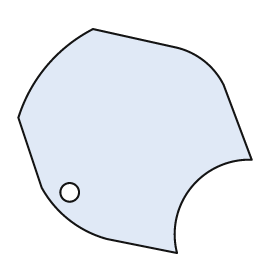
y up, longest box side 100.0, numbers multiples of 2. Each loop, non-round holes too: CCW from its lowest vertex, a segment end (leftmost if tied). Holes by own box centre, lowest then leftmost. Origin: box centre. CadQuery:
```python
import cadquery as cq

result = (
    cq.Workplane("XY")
    .moveTo(18.0, -48.0)
    .threePointArc((24.0, -20.0), (50.0, -8.0))
    .lineTo(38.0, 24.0)
    .threePointArc((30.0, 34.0), (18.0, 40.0))
    .lineTo(-18.0, 48.0)
    .threePointArc((-38.0, 32.0), (-50.0, 10.0))
    .lineTo(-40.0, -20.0)
    .threePointArc((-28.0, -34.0), (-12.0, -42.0))
    .close()
    .moveTo(-28.0, -22.0)
    .circle(4.0)
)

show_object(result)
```